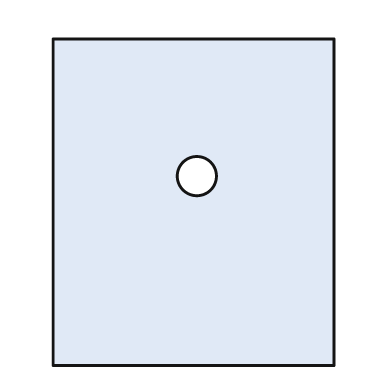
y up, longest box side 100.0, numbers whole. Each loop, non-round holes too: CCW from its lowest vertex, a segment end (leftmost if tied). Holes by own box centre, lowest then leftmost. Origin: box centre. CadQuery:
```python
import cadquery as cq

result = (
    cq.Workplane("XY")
    .moveTo(-43.0, -50.0)
    .lineTo(43.0, -50.0)
    .lineTo(43.0, 50.0)
    .lineTo(-43.0, 50.0)
    .close()
    .moveTo(1.0, 8.0)
    .circle(6.0)
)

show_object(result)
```